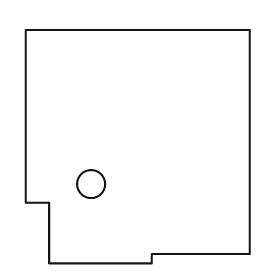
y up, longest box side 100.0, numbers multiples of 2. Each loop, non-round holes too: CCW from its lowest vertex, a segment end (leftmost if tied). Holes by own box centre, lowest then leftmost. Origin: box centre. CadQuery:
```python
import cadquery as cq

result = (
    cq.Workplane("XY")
    .moveTo(-38.0, -50.0)
    .lineTo(6.0, -50.0)
    .lineTo(6.0, -46.0)
    .lineTo(48.0, -46.0)
    .lineTo(48.0, 50.0)
    .lineTo(-48.0, 50.0)
    .lineTo(-48.0, -24.0)
    .lineTo(-38.0, -24.0)
    .close()
    .moveTo(-20.0, -16.0)
    .circle(6.0)
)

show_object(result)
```